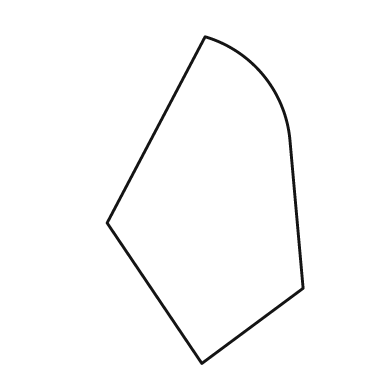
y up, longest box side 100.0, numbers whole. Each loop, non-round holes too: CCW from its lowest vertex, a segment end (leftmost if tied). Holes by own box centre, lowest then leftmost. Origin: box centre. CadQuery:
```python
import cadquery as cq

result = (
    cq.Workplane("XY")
    .moveTo(-1.0, -50.0)
    .lineTo(30.0, -27.0)
    .lineTo(26.0, 18.0)
    .threePointArc((18.0, 38.0), (0.0, 50.0))
    .lineTo(-30.0, -7.0)
    .close()
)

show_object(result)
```